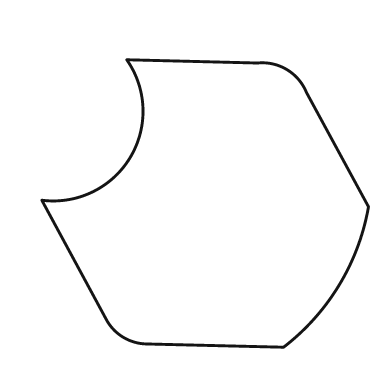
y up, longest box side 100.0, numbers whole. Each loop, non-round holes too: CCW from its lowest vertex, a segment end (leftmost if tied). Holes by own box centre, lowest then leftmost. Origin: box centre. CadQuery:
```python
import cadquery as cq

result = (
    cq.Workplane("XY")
    .moveTo(24.0, -44.0)
    .threePointArc((41.0, -25.0), (50.0, -1.0))
    .lineTo(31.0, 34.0)
    .threePointArc((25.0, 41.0), (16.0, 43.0))
    .lineTo(-24.0, 44.0)
    .threePointArc((-23.0, 14.0), (-50.0, 1.0))
    .lineTo(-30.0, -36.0)
    .threePointArc((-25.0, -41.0), (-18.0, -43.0))
    .close()
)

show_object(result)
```